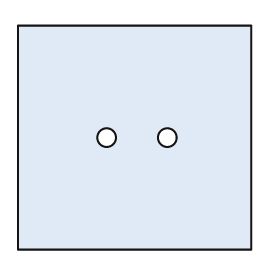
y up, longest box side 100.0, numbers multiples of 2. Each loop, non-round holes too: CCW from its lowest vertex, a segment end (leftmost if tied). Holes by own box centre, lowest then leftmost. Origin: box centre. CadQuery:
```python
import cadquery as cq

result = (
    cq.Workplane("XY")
    .moveTo(-50.0, -48.0)
    .lineTo(50.0, -48.0)
    .lineTo(50.0, 48.0)
    .lineTo(-50.0, 48.0)
    .close()
    .moveTo(-12.0, 0.0)
    .circle(4.0)
    .moveTo(14.0, 0.0)
    .circle(4.0)
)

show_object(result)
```